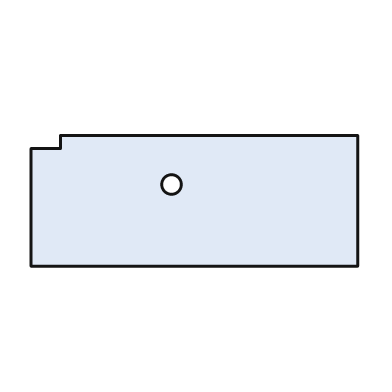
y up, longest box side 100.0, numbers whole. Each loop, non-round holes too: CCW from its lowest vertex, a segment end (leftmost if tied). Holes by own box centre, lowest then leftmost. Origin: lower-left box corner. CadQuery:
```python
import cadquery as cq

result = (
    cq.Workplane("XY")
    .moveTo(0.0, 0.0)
    .lineTo(100.0, 0.0)
    .lineTo(100.0, 40.0)
    .lineTo(9.0, 40.0)
    .lineTo(9.0, 36.0)
    .lineTo(0.0, 36.0)
    .close()
    .moveTo(43.0, 25.0)
    .circle(3.0)
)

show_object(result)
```